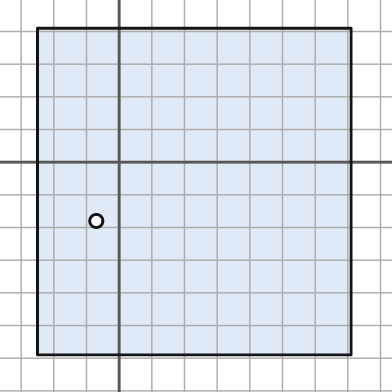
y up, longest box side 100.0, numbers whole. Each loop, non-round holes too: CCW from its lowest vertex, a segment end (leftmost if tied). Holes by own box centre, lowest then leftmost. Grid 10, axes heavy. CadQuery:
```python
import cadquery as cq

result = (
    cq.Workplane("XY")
    .moveTo(-25.0, -59.0)
    .lineTo(71.0, -59.0)
    .lineTo(71.0, 41.0)
    .lineTo(-25.0, 41.0)
    .close()
    .moveTo(-7.0, -18.0)
    .circle(2.0)
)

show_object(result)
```